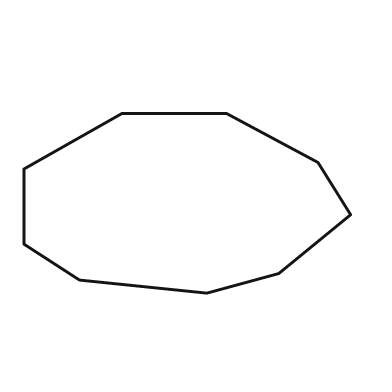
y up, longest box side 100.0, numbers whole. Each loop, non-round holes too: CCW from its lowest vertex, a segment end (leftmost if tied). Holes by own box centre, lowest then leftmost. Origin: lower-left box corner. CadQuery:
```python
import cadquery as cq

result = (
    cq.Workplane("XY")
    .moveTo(56.0, 0.0)
    .lineTo(78.0, 6.0)
    .lineTo(100.0, 24.0)
    .lineTo(90.0, 40.0)
    .lineTo(62.0, 55.0)
    .lineTo(30.0, 55.0)
    .lineTo(0.0, 38.0)
    .lineTo(0.0, 15.0)
    .lineTo(17.0, 4.0)
    .close()
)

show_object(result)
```